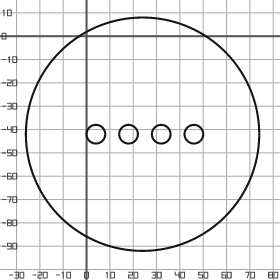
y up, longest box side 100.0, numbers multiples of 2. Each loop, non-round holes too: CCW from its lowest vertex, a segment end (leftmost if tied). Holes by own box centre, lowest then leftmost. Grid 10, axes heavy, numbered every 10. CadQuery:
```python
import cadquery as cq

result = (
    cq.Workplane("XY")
    .moveTo(24.0, -42.0)
    .circle(50.0)
    .moveTo(4.0, -42.0)
    .circle(4.0)
    .moveTo(18.0, -42.0)
    .circle(4.0)
    .moveTo(32.0, -42.0)
    .circle(4.0)
    .moveTo(46.0, -42.0)
    .circle(4.0)
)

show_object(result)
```